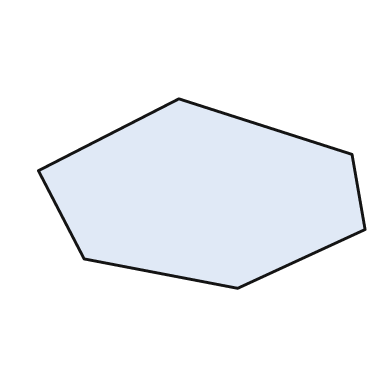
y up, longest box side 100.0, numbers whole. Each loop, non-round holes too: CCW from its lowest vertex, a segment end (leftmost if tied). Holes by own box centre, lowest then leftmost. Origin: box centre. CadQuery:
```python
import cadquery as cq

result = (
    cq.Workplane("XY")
    .moveTo(11.0, -29.0)
    .lineTo(50.0, -11.0)
    .lineTo(46.0, 12.0)
    .lineTo(-7.0, 29.0)
    .lineTo(-50.0, 7.0)
    .lineTo(-36.0, -20.0)
    .close()
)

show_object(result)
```